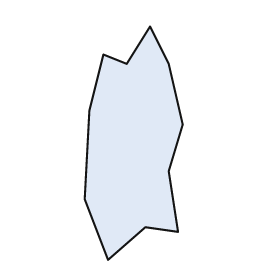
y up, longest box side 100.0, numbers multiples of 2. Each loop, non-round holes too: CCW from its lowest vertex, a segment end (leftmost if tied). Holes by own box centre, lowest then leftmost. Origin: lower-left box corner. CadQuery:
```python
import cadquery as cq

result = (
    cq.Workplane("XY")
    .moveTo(10.0, 0.0)
    .lineTo(26.0, 14.0)
    .lineTo(40.0, 12.0)
    .lineTo(36.0, 38.0)
    .lineTo(42.0, 58.0)
    .lineTo(36.0, 84.0)
    .lineTo(28.0, 100.0)
    .lineTo(18.0, 84.0)
    .lineTo(8.0, 88.0)
    .lineTo(2.0, 64.0)
    .lineTo(0.0, 26.0)
    .close()
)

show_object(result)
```